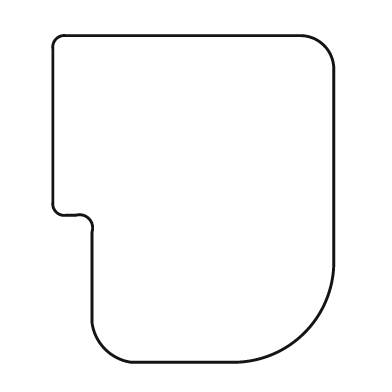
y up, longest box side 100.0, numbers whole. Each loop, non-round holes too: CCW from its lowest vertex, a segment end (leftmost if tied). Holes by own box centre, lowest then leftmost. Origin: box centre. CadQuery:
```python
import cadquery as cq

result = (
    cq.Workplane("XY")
    .moveTo(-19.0, -50.0)
    .lineTo(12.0, -50.0)
    .threePointArc((34.0, -41.0), (43.0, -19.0))
    .lineTo(43.0, 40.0)
    .threePointArc((40.0, 47.0), (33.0, 50.0))
    .lineTo(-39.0, 50.0)
    .threePointArc((-42.0, 49.0), (-43.0, 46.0))
    .lineTo(-43.0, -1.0)
    .threePointArc((-42.0, -4.0), (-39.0, -5.0))
    .lineTo(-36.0, -5.0)
    .threePointArc((-32.0, -6.0), (-31.0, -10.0))
    .lineTo(-31.0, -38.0)
    .threePointArc((-27.0, -46.0), (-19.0, -50.0))
    .close()
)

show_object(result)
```